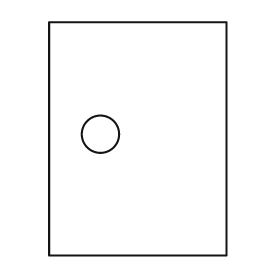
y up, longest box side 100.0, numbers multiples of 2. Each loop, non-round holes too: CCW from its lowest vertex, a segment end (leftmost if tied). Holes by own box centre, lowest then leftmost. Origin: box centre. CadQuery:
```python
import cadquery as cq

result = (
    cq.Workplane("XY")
    .moveTo(-38.0, -50.0)
    .lineTo(38.0, -50.0)
    .lineTo(38.0, 50.0)
    .lineTo(-38.0, 50.0)
    .close()
    .moveTo(-16.0, 2.0)
    .circle(8.0)
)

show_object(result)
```